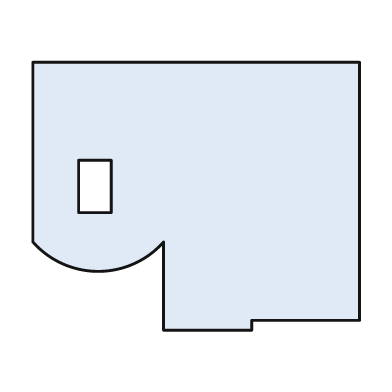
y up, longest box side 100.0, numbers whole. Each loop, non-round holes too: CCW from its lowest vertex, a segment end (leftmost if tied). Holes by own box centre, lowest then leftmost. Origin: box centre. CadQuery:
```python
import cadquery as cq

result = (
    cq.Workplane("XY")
    .moveTo(-10.0, -41.0)
    .lineTo(17.0, -41.0)
    .lineTo(17.0, -38.0)
    .lineTo(50.0, -38.0)
    .lineTo(50.0, 41.0)
    .lineTo(-50.0, 41.0)
    .lineTo(-50.0, -14.0)
    .threePointArc((-30.0, -23.0), (-10.0, -14.0))
    .close()
    .moveTo(-36.0, -5.0)
    .lineTo(-26.0, -5.0)
    .lineTo(-26.0, 11.0)
    .lineTo(-36.0, 11.0)
    .close()
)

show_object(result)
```